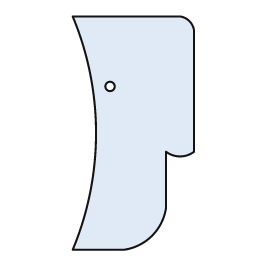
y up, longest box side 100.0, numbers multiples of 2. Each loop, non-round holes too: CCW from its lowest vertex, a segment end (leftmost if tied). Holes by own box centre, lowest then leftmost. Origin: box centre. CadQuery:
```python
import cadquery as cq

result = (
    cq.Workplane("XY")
    .moveTo(-26.0, -50.0)
    .lineTo(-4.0, -50.0)
    .threePointArc((8.0, -44.0), (14.0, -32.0))
    .lineTo(14.0, -8.0)
    .threePointArc((20.0, -10.0), (26.0, -8.0))
    .lineTo(26.0, 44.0)
    .threePointArc((24.0, 48.0), (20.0, 50.0))
    .lineTo(-26.0, 50.0)
    .threePointArc((-16.0, 0.0), (-26.0, -50.0))
    .close()
    .moveTo(-10.0, 20.0)
    .circle(2.0)
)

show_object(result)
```